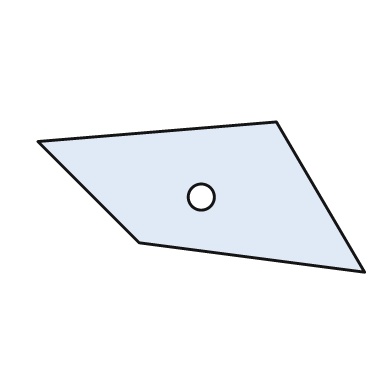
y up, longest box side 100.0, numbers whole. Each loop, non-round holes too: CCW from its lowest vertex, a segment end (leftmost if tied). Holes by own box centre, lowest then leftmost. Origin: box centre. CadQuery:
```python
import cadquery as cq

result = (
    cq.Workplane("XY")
    .moveTo(50.0, -23.0)
    .lineTo(23.0, 23.0)
    .lineTo(-50.0, 17.0)
    .lineTo(-19.0, -14.0)
    .close()
    .moveTo(0.0, 0.0)
    .circle(4.0)
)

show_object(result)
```